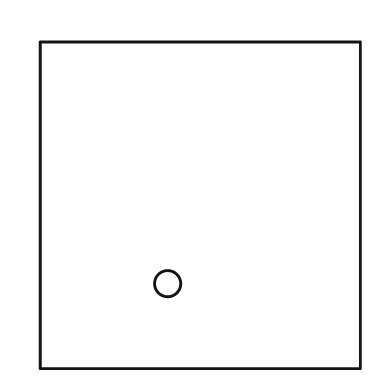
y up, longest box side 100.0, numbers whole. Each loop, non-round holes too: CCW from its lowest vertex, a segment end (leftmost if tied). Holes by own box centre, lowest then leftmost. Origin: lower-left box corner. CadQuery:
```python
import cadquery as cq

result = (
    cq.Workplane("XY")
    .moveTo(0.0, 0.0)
    .lineTo(98.0, 0.0)
    .lineTo(98.0, 100.0)
    .lineTo(0.0, 100.0)
    .close()
    .moveTo(39.0, 26.0)
    .circle(4.0)
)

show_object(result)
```